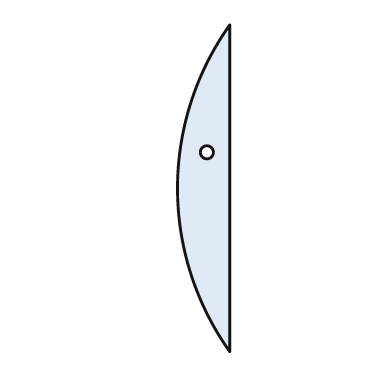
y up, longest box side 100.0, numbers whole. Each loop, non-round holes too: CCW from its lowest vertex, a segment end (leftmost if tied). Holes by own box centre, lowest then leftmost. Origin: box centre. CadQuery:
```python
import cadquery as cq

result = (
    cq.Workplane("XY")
    .moveTo(8.0, -50.0)
    .lineTo(8.0, 50.0)
    .threePointArc((-8.0, 0.0), (8.0, -50.0))
    .close()
    .moveTo(1.0, 11.0)
    .circle(2.0)
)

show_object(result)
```